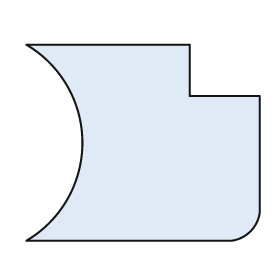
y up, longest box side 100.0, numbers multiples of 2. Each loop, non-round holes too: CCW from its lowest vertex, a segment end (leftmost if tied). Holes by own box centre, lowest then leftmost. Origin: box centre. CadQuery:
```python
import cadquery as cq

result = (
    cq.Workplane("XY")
    .moveTo(-50.0, -42.0)
    .lineTo(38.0, -42.0)
    .threePointArc((46.0, -38.0), (50.0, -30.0))
    .lineTo(50.0, 20.0)
    .lineTo(20.0, 20.0)
    .lineTo(20.0, 42.0)
    .lineTo(-50.0, 42.0)
    .threePointArc((-26.0, 0.0), (-50.0, -42.0))
    .close()
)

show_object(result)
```